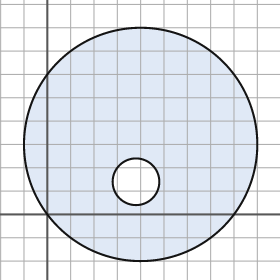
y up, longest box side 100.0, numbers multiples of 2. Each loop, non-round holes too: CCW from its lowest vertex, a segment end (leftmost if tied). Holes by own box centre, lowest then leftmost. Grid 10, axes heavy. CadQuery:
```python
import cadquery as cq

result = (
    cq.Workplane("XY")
    .moveTo(40.0, 30.0)
    .circle(50.0)
    .moveTo(38.0, 14.0)
    .circle(10.0)
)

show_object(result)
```